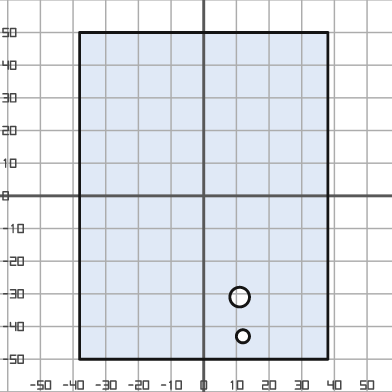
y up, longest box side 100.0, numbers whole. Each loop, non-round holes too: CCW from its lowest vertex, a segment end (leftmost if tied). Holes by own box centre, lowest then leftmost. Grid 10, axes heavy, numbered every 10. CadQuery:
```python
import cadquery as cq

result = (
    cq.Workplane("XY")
    .moveTo(-38.0, -50.0)
    .lineTo(38.0, -50.0)
    .lineTo(38.0, 50.0)
    .lineTo(-38.0, 50.0)
    .close()
    .moveTo(12.0, -43.0)
    .circle(2.0)
    .moveTo(11.0, -31.0)
    .circle(3.0)
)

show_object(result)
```